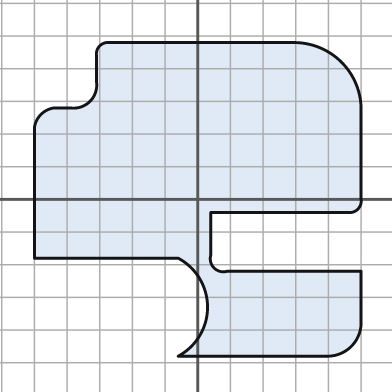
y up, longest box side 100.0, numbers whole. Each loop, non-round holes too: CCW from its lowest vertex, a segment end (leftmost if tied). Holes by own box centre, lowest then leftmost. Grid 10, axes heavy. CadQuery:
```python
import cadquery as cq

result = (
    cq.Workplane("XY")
    .moveTo(-6.0, -48.0)
    .lineTo(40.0, -48.0)
    .threePointArc((47.0, -45.0), (50.0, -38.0))
    .lineTo(50.0, -22.0)
    .lineTo(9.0, -22.0)
    .threePointArc((5.0, -21.0), (4.0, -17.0))
    .lineTo(4.0, -4.0)
    .lineTo(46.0, -4.0)
    .threePointArc((49.0, -3.0), (50.0, 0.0))
    .lineTo(50.0, 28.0)
    .threePointArc((44.0, 42.0), (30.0, 48.0))
    .lineTo(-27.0, 48.0)
    .threePointArc((-30.0, 47.0), (-31.0, 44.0))
    .lineTo(-31.0, 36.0)
    .threePointArc((-33.0, 30.0), (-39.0, 28.0))
    .lineTo(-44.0, 28.0)
    .threePointArc((-48.0, 26.0), (-50.0, 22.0))
    .lineTo(-50.0, -18.0)
    .lineTo(-6.0, -18.0)
    .threePointArc((3.0, -33.0), (-6.0, -48.0))
    .close()
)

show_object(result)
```